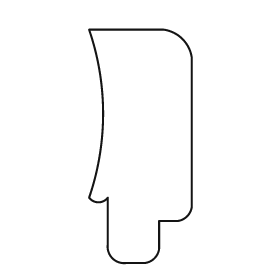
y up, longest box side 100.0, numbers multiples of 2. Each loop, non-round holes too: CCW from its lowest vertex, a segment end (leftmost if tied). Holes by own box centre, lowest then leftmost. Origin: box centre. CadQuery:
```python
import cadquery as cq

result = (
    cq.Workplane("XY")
    .moveTo(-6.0, -50.0)
    .lineTo(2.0, -50.0)
    .threePointArc((6.0, -48.0), (8.0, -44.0))
    .lineTo(8.0, -32.0)
    .lineTo(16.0, -32.0)
    .threePointArc((20.0, -30.0), (22.0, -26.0))
    .lineTo(22.0, 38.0)
    .threePointArc((18.0, 46.0), (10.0, 50.0))
    .lineTo(-22.0, 50.0)
    .threePointArc((-16.0, 14.0), (-22.0, -22.0))
    .threePointArc((-18.0, -24.0), (-14.0, -22.0))
    .lineTo(-14.0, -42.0)
    .threePointArc((-12.0, -48.0), (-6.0, -50.0))
    .close()
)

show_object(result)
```